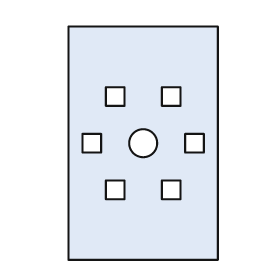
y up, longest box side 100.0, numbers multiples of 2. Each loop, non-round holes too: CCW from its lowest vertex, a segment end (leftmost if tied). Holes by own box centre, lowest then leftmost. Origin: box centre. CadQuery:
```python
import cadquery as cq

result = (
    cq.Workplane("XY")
    .moveTo(-32.0, -50.0)
    .lineTo(32.0, -50.0)
    .lineTo(32.0, 50.0)
    .lineTo(-32.0, 50.0)
    .close()
    .moveTo(-16.0, -24.0)
    .lineTo(-8.0, -24.0)
    .lineTo(-8.0, -16.0)
    .lineTo(-16.0, -16.0)
    .close()
    .moveTo(8.0, -24.0)
    .lineTo(16.0, -24.0)
    .lineTo(16.0, -16.0)
    .lineTo(8.0, -16.0)
    .close()
    .moveTo(-26.0, -4.0)
    .lineTo(-18.0, -4.0)
    .lineTo(-18.0, 4.0)
    .lineTo(-26.0, 4.0)
    .close()
    .moveTo(0.0, 0.0)
    .circle(6.0)
    .moveTo(18.0, -4.0)
    .lineTo(26.0, -4.0)
    .lineTo(26.0, 4.0)
    .lineTo(18.0, 4.0)
    .close()
    .moveTo(-16.0, 16.0)
    .lineTo(-8.0, 16.0)
    .lineTo(-8.0, 24.0)
    .lineTo(-16.0, 24.0)
    .close()
    .moveTo(8.0, 16.0)
    .lineTo(16.0, 16.0)
    .lineTo(16.0, 24.0)
    .lineTo(8.0, 24.0)
    .close()
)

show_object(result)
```